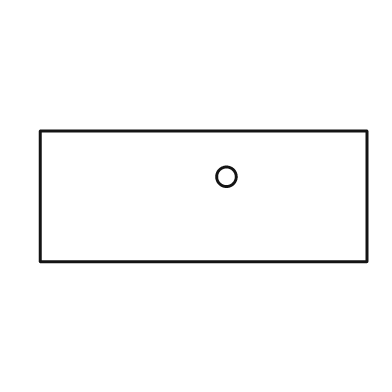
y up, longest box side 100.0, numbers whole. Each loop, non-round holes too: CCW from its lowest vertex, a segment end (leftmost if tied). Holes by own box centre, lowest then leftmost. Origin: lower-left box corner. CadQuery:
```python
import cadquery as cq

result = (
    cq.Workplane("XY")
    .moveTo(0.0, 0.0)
    .lineTo(100.0, 0.0)
    .lineTo(100.0, 40.0)
    .lineTo(0.0, 40.0)
    .close()
    .moveTo(57.0, 26.0)
    .circle(3.0)
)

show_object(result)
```